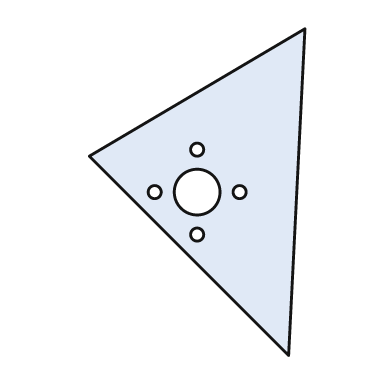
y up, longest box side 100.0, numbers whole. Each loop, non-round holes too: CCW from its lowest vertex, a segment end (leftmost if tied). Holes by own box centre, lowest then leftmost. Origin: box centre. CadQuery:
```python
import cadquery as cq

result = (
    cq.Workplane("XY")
    .moveTo(28.0, -50.0)
    .lineTo(33.0, 50.0)
    .lineTo(-33.0, 11.0)
    .close()
    .moveTo(0.0, -13.0)
    .circle(2.0)
    .moveTo(-13.0, 0.0)
    .circle(2.0)
    .moveTo(0.0, 0.0)
    .circle(7.0)
    .moveTo(13.0, 0.0)
    .circle(2.0)
    .moveTo(0.0, 13.0)
    .circle(2.0)
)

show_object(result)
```